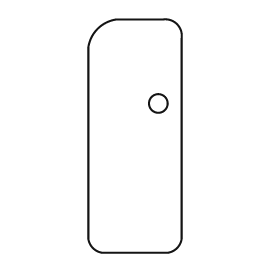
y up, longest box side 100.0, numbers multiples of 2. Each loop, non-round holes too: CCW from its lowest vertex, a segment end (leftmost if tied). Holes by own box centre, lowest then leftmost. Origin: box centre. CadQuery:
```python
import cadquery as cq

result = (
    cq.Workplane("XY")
    .moveTo(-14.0, -50.0)
    .lineTo(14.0, -50.0)
    .threePointArc((18.0, -48.0), (20.0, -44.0))
    .lineTo(20.0, 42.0)
    .threePointArc((18.0, 48.0), (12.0, 50.0))
    .lineTo(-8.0, 50.0)
    .threePointArc((-16.0, 46.0), (-20.0, 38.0))
    .lineTo(-20.0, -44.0)
    .threePointArc((-18.0, -48.0), (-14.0, -50.0))
    .close()
    .moveTo(10.0, 14.0)
    .circle(4.0)
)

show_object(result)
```